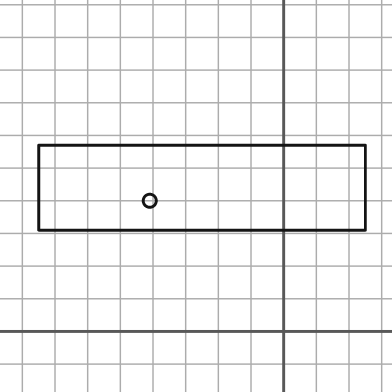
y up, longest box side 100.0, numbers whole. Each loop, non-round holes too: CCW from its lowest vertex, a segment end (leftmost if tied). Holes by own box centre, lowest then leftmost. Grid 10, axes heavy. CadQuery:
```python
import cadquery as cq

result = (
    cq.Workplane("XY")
    .moveTo(-75.0, 31.0)
    .lineTo(25.0, 31.0)
    .lineTo(25.0, 57.0)
    .lineTo(-75.0, 57.0)
    .close()
    .moveTo(-41.0, 40.0)
    .circle(2.0)
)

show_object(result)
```